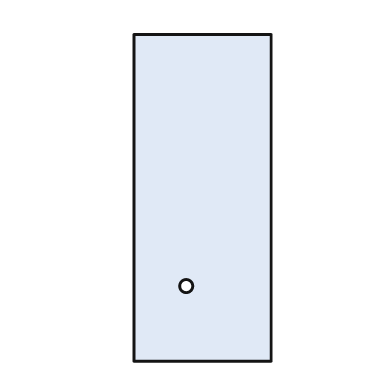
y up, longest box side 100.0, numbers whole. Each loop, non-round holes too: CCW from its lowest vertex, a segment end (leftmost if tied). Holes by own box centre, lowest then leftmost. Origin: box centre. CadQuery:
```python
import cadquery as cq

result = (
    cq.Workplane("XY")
    .moveTo(-21.0, -50.0)
    .lineTo(21.0, -50.0)
    .lineTo(21.0, 50.0)
    .lineTo(-21.0, 50.0)
    .close()
    .moveTo(-5.0, -27.0)
    .circle(2.0)
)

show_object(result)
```